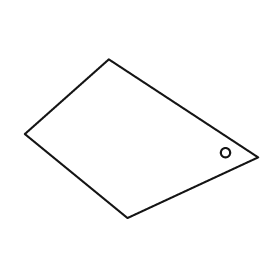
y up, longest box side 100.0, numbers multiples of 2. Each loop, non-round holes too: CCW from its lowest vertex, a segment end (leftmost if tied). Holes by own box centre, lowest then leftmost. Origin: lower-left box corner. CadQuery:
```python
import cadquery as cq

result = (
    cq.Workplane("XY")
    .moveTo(44.0, 0.0)
    .lineTo(100.0, 26.0)
    .lineTo(36.0, 68.0)
    .lineTo(0.0, 36.0)
    .close()
    .moveTo(86.0, 28.0)
    .circle(2.0)
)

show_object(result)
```